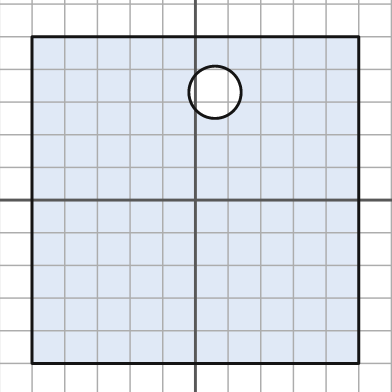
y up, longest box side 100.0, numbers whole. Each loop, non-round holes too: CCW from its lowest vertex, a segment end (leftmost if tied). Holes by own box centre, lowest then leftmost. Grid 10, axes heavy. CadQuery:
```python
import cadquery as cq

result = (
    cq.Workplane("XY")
    .moveTo(-50.0, -50.0)
    .lineTo(50.0, -50.0)
    .lineTo(50.0, 50.0)
    .lineTo(-50.0, 50.0)
    .close()
    .moveTo(6.0, 33.0)
    .circle(8.0)
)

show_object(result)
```